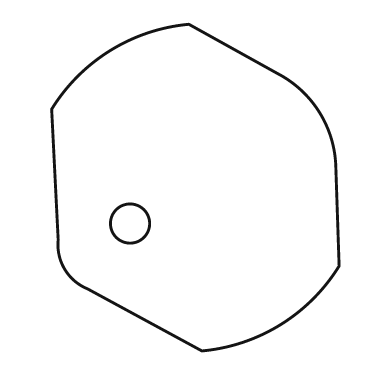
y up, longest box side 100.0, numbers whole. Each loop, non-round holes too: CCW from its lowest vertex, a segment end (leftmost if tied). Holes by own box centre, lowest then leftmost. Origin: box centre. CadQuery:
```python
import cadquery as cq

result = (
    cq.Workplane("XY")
    .moveTo(2.0, -50.0)
    .threePointArc((26.0, -42.0), (44.0, -24.0))
    .lineTo(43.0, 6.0)
    .threePointArc((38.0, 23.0), (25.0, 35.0))
    .lineTo(-2.0, 50.0)
    .threePointArc((-26.0, 42.0), (-44.0, 24.0))
    .lineTo(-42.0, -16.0)
    .threePointArc((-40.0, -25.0), (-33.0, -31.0))
    .close()
    .moveTo(-20.0, -11.0)
    .circle(6.0)
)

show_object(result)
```